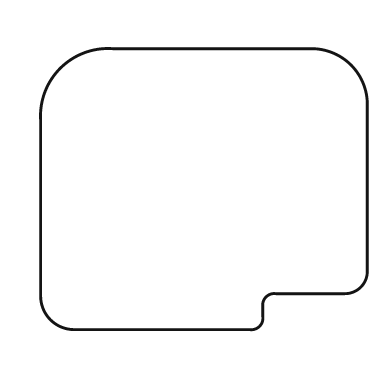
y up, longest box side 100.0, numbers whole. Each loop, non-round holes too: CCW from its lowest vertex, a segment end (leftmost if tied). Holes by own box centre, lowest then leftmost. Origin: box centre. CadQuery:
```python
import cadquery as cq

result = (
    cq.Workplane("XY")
    .moveTo(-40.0, -43.0)
    .lineTo(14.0, -43.0)
    .threePointArc((17.0, -42.0), (18.0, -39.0))
    .lineTo(18.0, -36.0)
    .threePointArc((19.0, -33.0), (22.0, -32.0))
    .lineTo(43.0, -32.0)
    .threePointArc((48.0, -30.0), (50.0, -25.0))
    .lineTo(50.0, 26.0)
    .threePointArc((45.0, 38.0), (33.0, 43.0))
    .lineTo(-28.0, 43.0)
    .threePointArc((-44.0, 37.0), (-50.0, 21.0))
    .lineTo(-50.0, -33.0)
    .threePointArc((-47.0, -40.0), (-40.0, -43.0))
    .close()
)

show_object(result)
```